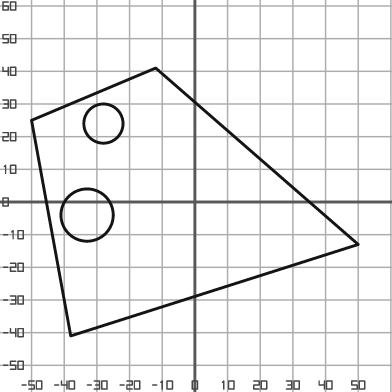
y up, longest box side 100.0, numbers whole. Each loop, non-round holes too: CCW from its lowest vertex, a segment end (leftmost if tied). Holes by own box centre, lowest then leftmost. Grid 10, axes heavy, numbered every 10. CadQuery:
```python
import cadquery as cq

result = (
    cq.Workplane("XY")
    .moveTo(-38.0, -41.0)
    .lineTo(50.0, -13.0)
    .lineTo(-12.0, 41.0)
    .lineTo(-50.0, 25.0)
    .close()
    .moveTo(-33.0, -4.0)
    .circle(8.0)
    .moveTo(-28.0, 24.0)
    .circle(6.0)
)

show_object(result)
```